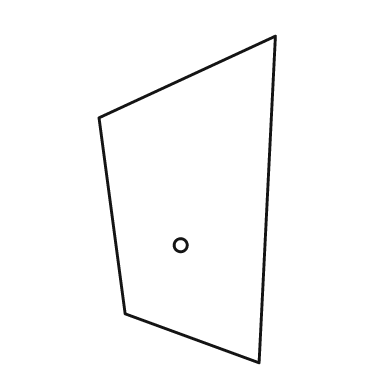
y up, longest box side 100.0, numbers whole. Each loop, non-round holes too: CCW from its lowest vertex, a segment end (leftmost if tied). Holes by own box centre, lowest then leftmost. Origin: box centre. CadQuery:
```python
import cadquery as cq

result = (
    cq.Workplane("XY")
    .moveTo(22.0, -50.0)
    .lineTo(27.0, 50.0)
    .lineTo(-27.0, 25.0)
    .lineTo(-19.0, -35.0)
    .close()
    .moveTo(-2.0, -14.0)
    .circle(2.0)
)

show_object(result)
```